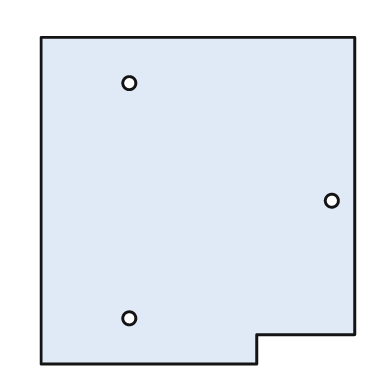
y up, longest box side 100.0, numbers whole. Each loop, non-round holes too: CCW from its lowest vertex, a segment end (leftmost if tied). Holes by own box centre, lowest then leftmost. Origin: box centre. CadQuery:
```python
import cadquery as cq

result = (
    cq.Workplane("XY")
    .moveTo(-48.0, -50.0)
    .lineTo(18.0, -50.0)
    .lineTo(18.0, -41.0)
    .lineTo(48.0, -41.0)
    .lineTo(48.0, 50.0)
    .lineTo(-48.0, 50.0)
    .close()
    .moveTo(-21.0, -36.0)
    .circle(2.0)
    .moveTo(41.0, 0.0)
    .circle(2.0)
    .moveTo(-21.0, 36.0)
    .circle(2.0)
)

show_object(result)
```